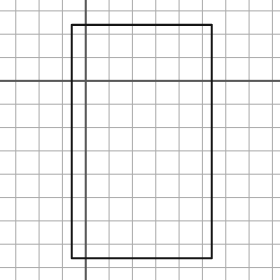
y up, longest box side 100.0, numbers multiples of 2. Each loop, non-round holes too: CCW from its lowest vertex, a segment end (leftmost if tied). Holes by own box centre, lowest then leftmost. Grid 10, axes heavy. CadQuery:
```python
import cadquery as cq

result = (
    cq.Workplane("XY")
    .moveTo(-6.0, -76.0)
    .lineTo(54.0, -76.0)
    .lineTo(54.0, 24.0)
    .lineTo(-6.0, 24.0)
    .close()
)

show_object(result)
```